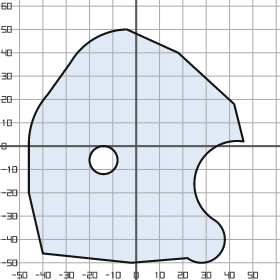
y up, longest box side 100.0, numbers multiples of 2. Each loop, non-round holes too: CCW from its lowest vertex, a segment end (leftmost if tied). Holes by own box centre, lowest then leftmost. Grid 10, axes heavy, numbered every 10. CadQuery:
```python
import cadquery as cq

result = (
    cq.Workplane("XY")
    .moveTo(-2.0, -50.0)
    .lineTo(22.0, -48.0)
    .threePointArc((36.0, -46.0), (34.0, -32.0))
    .threePointArc((26.0, -10.0), (46.0, 2.0))
    .lineTo(42.0, 18.0)
    .lineTo(18.0, 40.0)
    .lineTo(-4.0, 50.0)
    .threePointArc((-18.0, 46.0), (-28.0, 36.0))
    .lineTo(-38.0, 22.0)
    .threePointArc((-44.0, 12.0), (-46.0, 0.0))
    .lineTo(-46.0, -20.0)
    .lineTo(-40.0, -46.0)
    .close()
    .moveTo(-14.0, -6.0)
    .circle(6.0)
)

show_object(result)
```